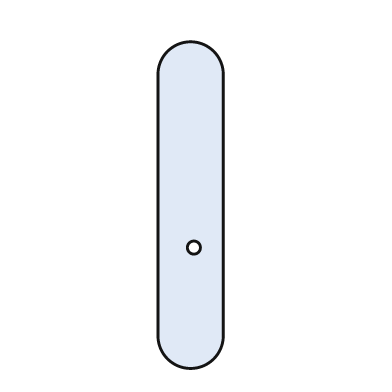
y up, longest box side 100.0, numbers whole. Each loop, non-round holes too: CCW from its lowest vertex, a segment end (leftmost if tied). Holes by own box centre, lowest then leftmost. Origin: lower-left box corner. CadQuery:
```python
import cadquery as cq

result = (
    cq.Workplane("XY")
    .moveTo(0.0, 10.0)
    .threePointArc((10.0, 0.0), (20.0, 10.0))
    .lineTo(20.0, 90.0)
    .threePointArc((10.0, 100.0), (0.0, 90.0))
    .close()
    .moveTo(11.0, 37.0)
    .circle(2.0)
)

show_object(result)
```